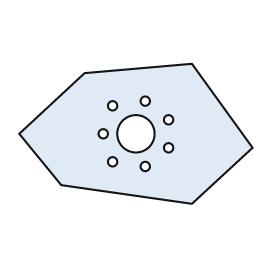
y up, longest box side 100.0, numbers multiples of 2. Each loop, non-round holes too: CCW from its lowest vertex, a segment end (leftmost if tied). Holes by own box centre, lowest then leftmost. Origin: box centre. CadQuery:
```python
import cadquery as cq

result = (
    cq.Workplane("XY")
    .moveTo(24.0, -30.0)
    .lineTo(50.0, -6.0)
    .lineTo(24.0, 30.0)
    .lineTo(-22.0, 26.0)
    .lineTo(-50.0, 0.0)
    .lineTo(-32.0, -22.0)
    .close()
    .moveTo(4.0, -14.0)
    .circle(2.0)
    .moveTo(-10.0, -12.0)
    .circle(2.0)
    .moveTo(14.0, -6.0)
    .circle(2.0)
    .moveTo(-14.0, 0.0)
    .circle(2.0)
    .moveTo(0.0, 0.0)
    .circle(8.0)
    .moveTo(14.0, 6.0)
    .circle(2.0)
    .moveTo(-10.0, 12.0)
    .circle(2.0)
    .moveTo(4.0, 14.0)
    .circle(2.0)
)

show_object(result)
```